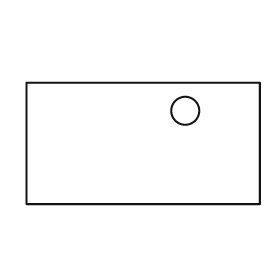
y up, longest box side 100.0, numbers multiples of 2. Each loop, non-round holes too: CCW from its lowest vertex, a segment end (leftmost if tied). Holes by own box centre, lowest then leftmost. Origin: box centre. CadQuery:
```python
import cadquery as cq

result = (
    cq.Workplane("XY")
    .moveTo(-50.0, -26.0)
    .lineTo(50.0, -26.0)
    .lineTo(50.0, 26.0)
    .lineTo(-50.0, 26.0)
    .close()
    .moveTo(18.0, 14.0)
    .circle(6.0)
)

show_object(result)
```